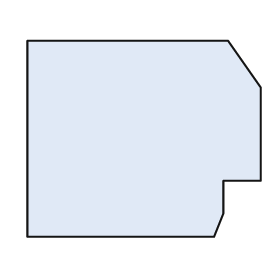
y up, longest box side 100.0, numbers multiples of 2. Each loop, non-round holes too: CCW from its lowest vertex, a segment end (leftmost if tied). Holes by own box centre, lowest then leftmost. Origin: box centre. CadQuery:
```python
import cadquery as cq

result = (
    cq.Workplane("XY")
    .moveTo(-50.0, -42.0)
    .lineTo(30.0, -42.0)
    .lineTo(34.0, -32.0)
    .lineTo(34.0, -18.0)
    .lineTo(50.0, -18.0)
    .lineTo(50.0, 22.0)
    .lineTo(36.0, 42.0)
    .lineTo(-50.0, 42.0)
    .close()
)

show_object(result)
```